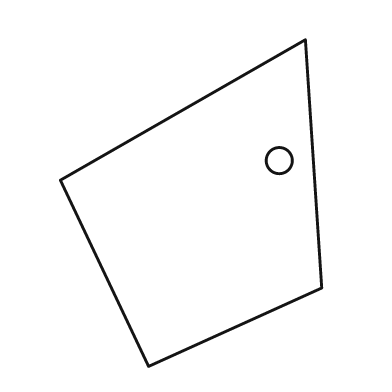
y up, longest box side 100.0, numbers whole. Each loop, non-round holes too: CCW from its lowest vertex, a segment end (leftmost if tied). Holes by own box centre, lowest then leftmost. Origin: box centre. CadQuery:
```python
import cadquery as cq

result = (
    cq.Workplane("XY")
    .moveTo(-13.0, -50.0)
    .lineTo(40.0, -26.0)
    .lineTo(35.0, 50.0)
    .lineTo(-40.0, 7.0)
    .close()
    .moveTo(27.0, 13.0)
    .circle(4.0)
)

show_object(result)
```